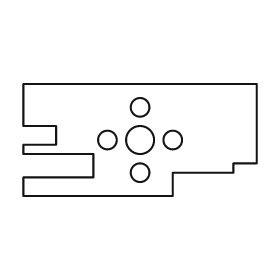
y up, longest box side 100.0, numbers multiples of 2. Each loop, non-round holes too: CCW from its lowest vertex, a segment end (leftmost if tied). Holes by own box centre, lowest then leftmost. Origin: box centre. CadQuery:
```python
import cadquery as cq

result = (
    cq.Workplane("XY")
    .moveTo(-50.0, -24.0)
    .lineTo(14.0, -24.0)
    .lineTo(14.0, -14.0)
    .lineTo(40.0, -14.0)
    .lineTo(40.0, -10.0)
    .lineTo(50.0, -10.0)
    .lineTo(50.0, 24.0)
    .lineTo(-50.0, 24.0)
    .lineTo(-50.0, 6.0)
    .lineTo(-36.0, 6.0)
    .lineTo(-36.0, -2.0)
    .lineTo(-50.0, -2.0)
    .lineTo(-50.0, -6.0)
    .lineTo(-20.0, -6.0)
    .lineTo(-20.0, -16.0)
    .lineTo(-50.0, -16.0)
    .close()
    .moveTo(0.0, -14.0)
    .circle(4.0)
    .moveTo(-14.0, 0.0)
    .circle(4.0)
    .moveTo(0.0, 0.0)
    .circle(6.0)
    .moveTo(14.0, 0.0)
    .circle(4.0)
    .moveTo(0.0, 14.0)
    .circle(4.0)
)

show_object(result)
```